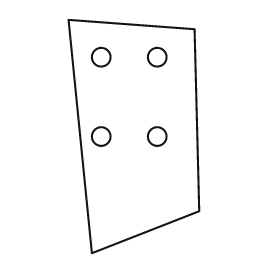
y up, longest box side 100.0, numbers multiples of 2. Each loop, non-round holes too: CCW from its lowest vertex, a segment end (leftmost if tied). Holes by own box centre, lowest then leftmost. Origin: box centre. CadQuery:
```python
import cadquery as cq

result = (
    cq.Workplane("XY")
    .moveTo(-18.0, -50.0)
    .lineTo(28.0, -32.0)
    .lineTo(26.0, 46.0)
    .lineTo(-28.0, 50.0)
    .close()
    .moveTo(-14.0, 0.0)
    .circle(4.0)
    .moveTo(10.0, 0.0)
    .circle(4.0)
    .moveTo(-14.0, 34.0)
    .circle(4.0)
    .moveTo(10.0, 34.0)
    .circle(4.0)
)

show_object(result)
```